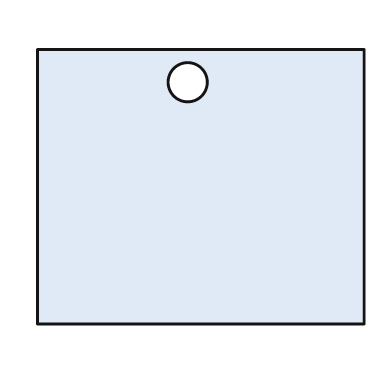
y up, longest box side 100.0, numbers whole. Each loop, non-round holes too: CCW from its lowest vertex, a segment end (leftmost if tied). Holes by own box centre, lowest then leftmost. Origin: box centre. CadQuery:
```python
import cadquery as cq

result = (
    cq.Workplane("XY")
    .moveTo(-50.0, -42.0)
    .lineTo(50.0, -42.0)
    .lineTo(50.0, 42.0)
    .lineTo(-50.0, 42.0)
    .close()
    .moveTo(-4.0, 32.0)
    .circle(6.0)
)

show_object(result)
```